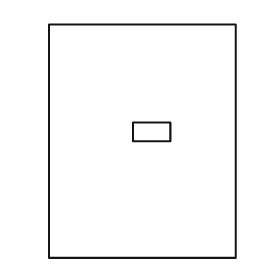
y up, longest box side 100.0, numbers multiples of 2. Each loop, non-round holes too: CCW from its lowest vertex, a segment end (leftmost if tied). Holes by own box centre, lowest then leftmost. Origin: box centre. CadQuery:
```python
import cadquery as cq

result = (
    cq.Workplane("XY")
    .moveTo(-40.0, -50.0)
    .lineTo(40.0, -50.0)
    .lineTo(40.0, 50.0)
    .lineTo(-40.0, 50.0)
    .close()
    .moveTo(-4.0, 0.0)
    .lineTo(12.0, 0.0)
    .lineTo(12.0, 8.0)
    .lineTo(-4.0, 8.0)
    .close()
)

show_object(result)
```